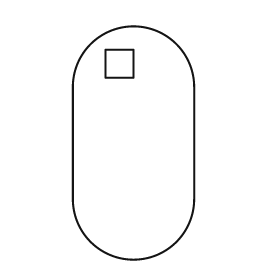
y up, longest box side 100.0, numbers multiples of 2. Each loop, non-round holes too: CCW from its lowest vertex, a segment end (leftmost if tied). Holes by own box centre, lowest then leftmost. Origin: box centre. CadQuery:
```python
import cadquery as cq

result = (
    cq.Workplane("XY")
    .moveTo(-26.0, -24.0)
    .threePointArc((0.0, -50.0), (26.0, -24.0))
    .lineTo(26.0, 24.0)
    .threePointArc((0.0, 50.0), (-26.0, 24.0))
    .close()
    .moveTo(-12.0, 28.0)
    .lineTo(0.0, 28.0)
    .lineTo(0.0, 40.0)
    .lineTo(-12.0, 40.0)
    .close()
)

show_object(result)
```